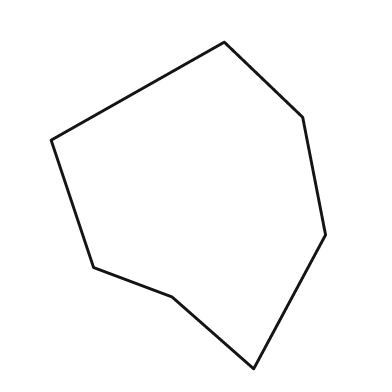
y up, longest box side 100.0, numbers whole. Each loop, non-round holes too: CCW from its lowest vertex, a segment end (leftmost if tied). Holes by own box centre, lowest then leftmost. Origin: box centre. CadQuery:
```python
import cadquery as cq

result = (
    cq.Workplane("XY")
    .moveTo(20.0, -50.0)
    .lineTo(42.0, -9.0)
    .lineTo(35.0, 27.0)
    .lineTo(11.0, 50.0)
    .lineTo(-42.0, 20.0)
    .lineTo(-29.0, -19.0)
    .lineTo(-5.0, -28.0)
    .close()
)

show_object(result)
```